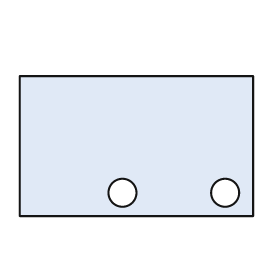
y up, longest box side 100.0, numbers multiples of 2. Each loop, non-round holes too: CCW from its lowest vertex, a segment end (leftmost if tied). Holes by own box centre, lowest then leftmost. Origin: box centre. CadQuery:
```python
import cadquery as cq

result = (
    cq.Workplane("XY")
    .moveTo(-50.0, -30.0)
    .lineTo(50.0, -30.0)
    .lineTo(50.0, 30.0)
    .lineTo(-50.0, 30.0)
    .close()
    .moveTo(-6.0, -20.0)
    .circle(6.0)
    .moveTo(38.0, -20.0)
    .circle(6.0)
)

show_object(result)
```